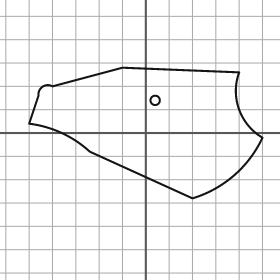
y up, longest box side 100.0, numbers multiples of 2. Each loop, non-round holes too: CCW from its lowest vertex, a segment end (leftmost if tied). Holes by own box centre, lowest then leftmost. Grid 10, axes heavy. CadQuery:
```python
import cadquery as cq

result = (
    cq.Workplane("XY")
    .moveTo(20.0, -28.0)
    .threePointArc((38.0, -18.0), (50.0, -2.0))
    .threePointArc((40.0, 10.0), (40.0, 26.0))
    .lineTo(-10.0, 28.0)
    .lineTo(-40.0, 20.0)
    .threePointArc((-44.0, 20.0), (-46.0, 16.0))
    .lineTo(-50.0, 4.0)
    .threePointArc((-36.0, 0.0), (-24.0, -8.0))
    .close()
    .moveTo(4.0, 14.0)
    .circle(2.0)
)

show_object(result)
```